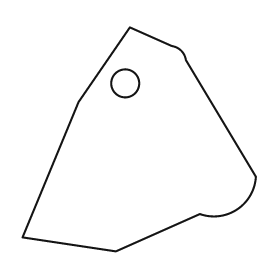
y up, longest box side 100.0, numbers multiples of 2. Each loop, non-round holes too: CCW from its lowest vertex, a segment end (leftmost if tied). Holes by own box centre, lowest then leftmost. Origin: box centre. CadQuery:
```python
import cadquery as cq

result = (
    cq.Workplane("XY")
    .moveTo(-10.0, -48.0)
    .lineTo(26.0, -32.0)
    .threePointArc((42.0, -30.0), (50.0, -16.0))
    .lineTo(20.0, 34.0)
    .threePointArc((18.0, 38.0), (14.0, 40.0))
    .lineTo(-4.0, 48.0)
    .lineTo(-26.0, 16.0)
    .lineTo(-50.0, -42.0)
    .close()
    .moveTo(-6.0, 24.0)
    .circle(6.0)
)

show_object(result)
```